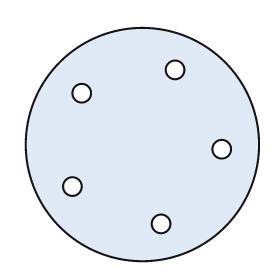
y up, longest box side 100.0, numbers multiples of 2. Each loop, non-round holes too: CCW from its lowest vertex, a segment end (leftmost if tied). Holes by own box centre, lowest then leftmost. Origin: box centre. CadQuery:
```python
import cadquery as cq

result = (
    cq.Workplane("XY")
    .moveTo(0.0, 0.0)
    .circle(50.0)
    .moveTo(8.0, -34.0)
    .circle(4.0)
    .moveTo(-30.0, -18.0)
    .circle(4.0)
    .moveTo(34.0, -2.0)
    .circle(4.0)
    .moveTo(-26.0, 22.0)
    .circle(4.0)
    .moveTo(14.0, 32.0)
    .circle(4.0)
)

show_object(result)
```